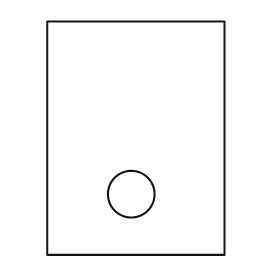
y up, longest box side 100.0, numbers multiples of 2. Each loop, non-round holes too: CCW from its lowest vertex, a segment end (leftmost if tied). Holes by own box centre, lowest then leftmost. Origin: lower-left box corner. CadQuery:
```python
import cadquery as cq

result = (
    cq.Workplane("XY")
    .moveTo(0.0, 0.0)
    .lineTo(76.0, 0.0)
    .lineTo(76.0, 100.0)
    .lineTo(0.0, 100.0)
    .close()
    .moveTo(36.0, 26.0)
    .circle(10.0)
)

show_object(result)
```